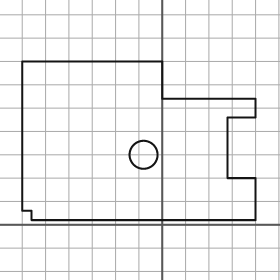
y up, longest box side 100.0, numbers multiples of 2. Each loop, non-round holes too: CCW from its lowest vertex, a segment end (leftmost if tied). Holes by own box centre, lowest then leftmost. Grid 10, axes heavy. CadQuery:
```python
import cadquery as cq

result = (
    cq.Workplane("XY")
    .moveTo(-56.0, 2.0)
    .lineTo(40.0, 2.0)
    .lineTo(40.0, 20.0)
    .lineTo(28.0, 20.0)
    .lineTo(28.0, 46.0)
    .lineTo(40.0, 46.0)
    .lineTo(40.0, 54.0)
    .lineTo(0.0, 54.0)
    .lineTo(0.0, 70.0)
    .lineTo(-60.0, 70.0)
    .lineTo(-60.0, 6.0)
    .lineTo(-56.0, 6.0)
    .close()
    .moveTo(-8.0, 30.0)
    .circle(6.0)
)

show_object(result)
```